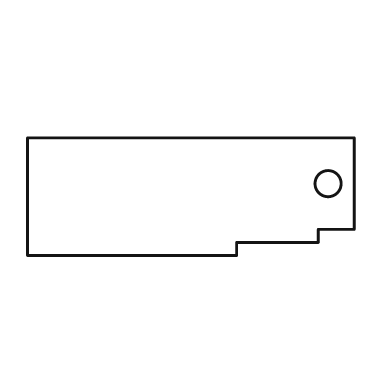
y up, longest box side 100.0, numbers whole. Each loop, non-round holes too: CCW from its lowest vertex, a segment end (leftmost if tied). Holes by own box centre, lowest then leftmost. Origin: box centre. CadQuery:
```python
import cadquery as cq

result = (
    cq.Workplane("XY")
    .moveTo(-50.0, -18.0)
    .lineTo(14.0, -18.0)
    .lineTo(14.0, -14.0)
    .lineTo(39.0, -14.0)
    .lineTo(39.0, -10.0)
    .lineTo(50.0, -10.0)
    .lineTo(50.0, 18.0)
    .lineTo(-50.0, 18.0)
    .close()
    .moveTo(42.0, 4.0)
    .circle(4.0)
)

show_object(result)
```